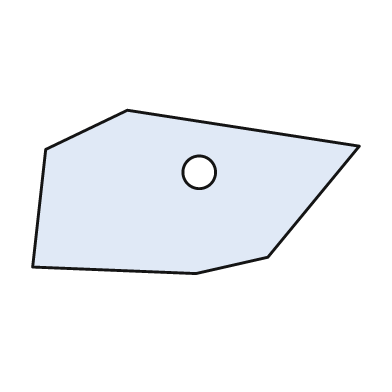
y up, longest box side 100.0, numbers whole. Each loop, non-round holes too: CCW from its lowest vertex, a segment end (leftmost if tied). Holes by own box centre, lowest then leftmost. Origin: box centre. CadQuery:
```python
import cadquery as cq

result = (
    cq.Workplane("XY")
    .moveTo(0.0, -25.0)
    .lineTo(22.0, -20.0)
    .lineTo(50.0, 14.0)
    .lineTo(-21.0, 25.0)
    .lineTo(-46.0, 13.0)
    .lineTo(-50.0, -23.0)
    .close()
    .moveTo(1.0, 6.0)
    .circle(5.0)
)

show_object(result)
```